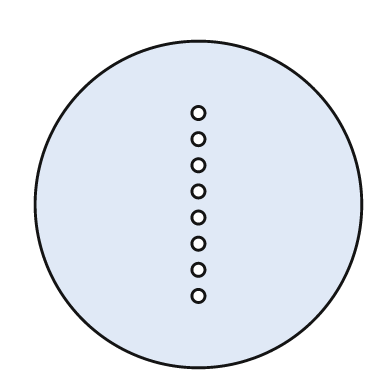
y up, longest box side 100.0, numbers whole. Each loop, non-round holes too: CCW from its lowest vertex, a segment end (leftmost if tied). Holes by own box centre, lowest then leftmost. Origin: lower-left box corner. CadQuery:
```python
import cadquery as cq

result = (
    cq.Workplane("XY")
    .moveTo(50.0, 50.0)
    .circle(50.0)
    .moveTo(50.0, 22.0)
    .circle(2.0)
    .moveTo(50.0, 30.0)
    .circle(2.0)
    .moveTo(50.0, 38.0)
    .circle(2.0)
    .moveTo(50.0, 46.0)
    .circle(2.0)
    .moveTo(50.0, 54.0)
    .circle(2.0)
    .moveTo(50.0, 62.0)
    .circle(2.0)
    .moveTo(50.0, 70.0)
    .circle(2.0)
    .moveTo(50.0, 78.0)
    .circle(2.0)
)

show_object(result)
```